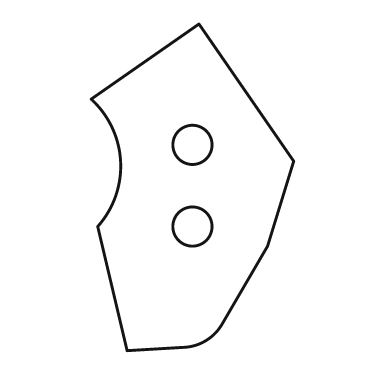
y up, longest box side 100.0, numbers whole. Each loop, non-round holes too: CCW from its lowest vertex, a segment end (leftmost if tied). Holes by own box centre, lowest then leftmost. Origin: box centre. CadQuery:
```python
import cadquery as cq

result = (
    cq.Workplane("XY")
    .moveTo(-20.0, -50.0)
    .lineTo(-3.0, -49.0)
    .threePointArc((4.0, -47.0), (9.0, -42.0))
    .lineTo(23.0, -18.0)
    .lineTo(31.0, 8.0)
    .lineTo(2.0, 50.0)
    .lineTo(-31.0, 27.0)
    .threePointArc((-22.0, 8.0), (-29.0, -12.0))
    .close()
    .moveTo(0.0, -12.0)
    .circle(6.0)
    .moveTo(0.0, 13.0)
    .circle(6.0)
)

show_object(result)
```